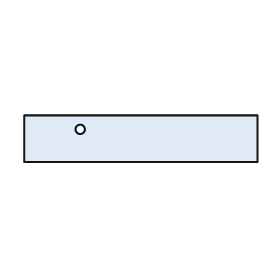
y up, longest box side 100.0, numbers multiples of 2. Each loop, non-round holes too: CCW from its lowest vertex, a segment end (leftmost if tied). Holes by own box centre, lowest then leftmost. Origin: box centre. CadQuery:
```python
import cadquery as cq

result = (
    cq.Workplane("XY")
    .moveTo(-50.0, -10.0)
    .lineTo(50.0, -10.0)
    .lineTo(50.0, 10.0)
    .lineTo(-50.0, 10.0)
    .close()
    .moveTo(-26.0, 4.0)
    .circle(2.0)
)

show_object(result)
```